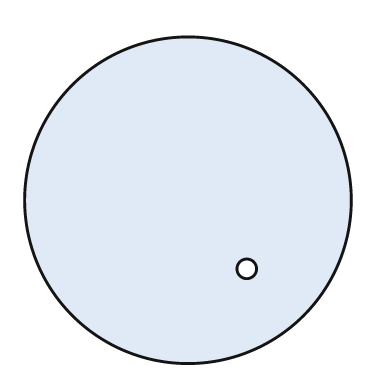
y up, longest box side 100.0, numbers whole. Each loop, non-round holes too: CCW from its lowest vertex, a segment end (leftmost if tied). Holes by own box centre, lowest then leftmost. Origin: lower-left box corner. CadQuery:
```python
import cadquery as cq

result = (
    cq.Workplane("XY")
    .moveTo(50.0, 50.0)
    .circle(50.0)
    .moveTo(68.0, 29.0)
    .circle(3.0)
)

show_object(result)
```